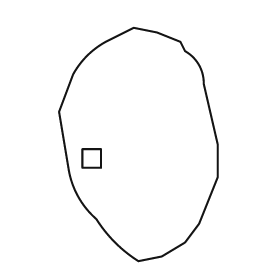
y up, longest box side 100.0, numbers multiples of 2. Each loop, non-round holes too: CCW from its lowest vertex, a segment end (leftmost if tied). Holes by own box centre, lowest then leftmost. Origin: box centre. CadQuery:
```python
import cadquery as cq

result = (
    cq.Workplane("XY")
    .moveTo(0.0, -50.0)
    .lineTo(10.0, -48.0)
    .lineTo(20.0, -42.0)
    .lineTo(26.0, -34.0)
    .lineTo(34.0, -14.0)
    .lineTo(34.0, 0.0)
    .lineTo(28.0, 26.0)
    .threePointArc((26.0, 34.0), (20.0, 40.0))
    .lineTo(18.0, 44.0)
    .lineTo(8.0, 48.0)
    .lineTo(-2.0, 50.0)
    .lineTo(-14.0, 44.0)
    .threePointArc((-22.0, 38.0), (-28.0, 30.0))
    .lineTo(-34.0, 14.0)
    .lineTo(-30.0, -10.0)
    .threePointArc((-26.0, -22.0), (-18.0, -32.0))
    .threePointArc((-10.0, -42.0), (0.0, -50.0))
    .close()
    .moveTo(-24.0, -10.0)
    .lineTo(-16.0, -10.0)
    .lineTo(-16.0, -2.0)
    .lineTo(-24.0, -2.0)
    .close()
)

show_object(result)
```